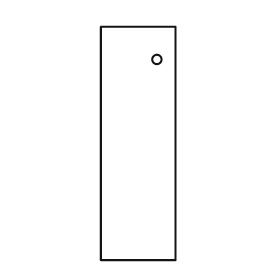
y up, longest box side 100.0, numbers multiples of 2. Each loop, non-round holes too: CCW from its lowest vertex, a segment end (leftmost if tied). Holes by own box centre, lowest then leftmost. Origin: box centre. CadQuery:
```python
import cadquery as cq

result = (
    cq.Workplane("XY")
    .moveTo(-16.0, -50.0)
    .lineTo(16.0, -50.0)
    .lineTo(16.0, 50.0)
    .lineTo(-16.0, 50.0)
    .close()
    .moveTo(8.0, 36.0)
    .circle(2.0)
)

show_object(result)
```